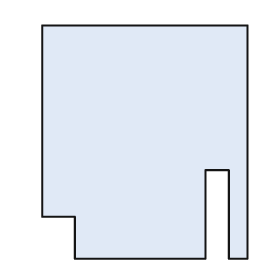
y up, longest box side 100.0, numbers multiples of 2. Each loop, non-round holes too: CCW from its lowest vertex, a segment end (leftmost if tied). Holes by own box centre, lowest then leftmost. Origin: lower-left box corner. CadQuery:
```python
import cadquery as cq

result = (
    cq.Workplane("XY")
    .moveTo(14.0, 0.0)
    .lineTo(70.0, 0.0)
    .lineTo(70.0, 38.0)
    .lineTo(80.0, 38.0)
    .lineTo(80.0, 0.0)
    .lineTo(88.0, 0.0)
    .lineTo(88.0, 100.0)
    .lineTo(0.0, 100.0)
    .lineTo(0.0, 18.0)
    .lineTo(14.0, 18.0)
    .close()
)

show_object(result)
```